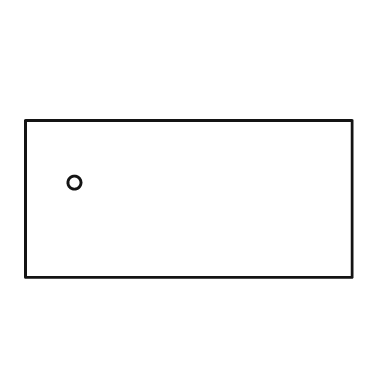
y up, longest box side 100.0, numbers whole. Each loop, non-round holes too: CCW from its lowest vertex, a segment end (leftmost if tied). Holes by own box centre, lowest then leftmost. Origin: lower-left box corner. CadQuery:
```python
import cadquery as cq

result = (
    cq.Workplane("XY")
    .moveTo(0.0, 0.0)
    .lineTo(100.0, 0.0)
    .lineTo(100.0, 48.0)
    .lineTo(0.0, 48.0)
    .close()
    .moveTo(15.0, 29.0)
    .circle(2.0)
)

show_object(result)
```